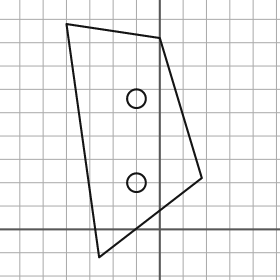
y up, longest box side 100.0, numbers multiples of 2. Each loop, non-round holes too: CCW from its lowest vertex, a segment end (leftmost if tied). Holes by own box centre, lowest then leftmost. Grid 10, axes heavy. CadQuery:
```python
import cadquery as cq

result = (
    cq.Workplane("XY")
    .moveTo(-26.0, -12.0)
    .lineTo(18.0, 22.0)
    .lineTo(0.0, 82.0)
    .lineTo(-40.0, 88.0)
    .close()
    .moveTo(-10.0, 20.0)
    .circle(4.0)
    .moveTo(-10.0, 56.0)
    .circle(4.0)
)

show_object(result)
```